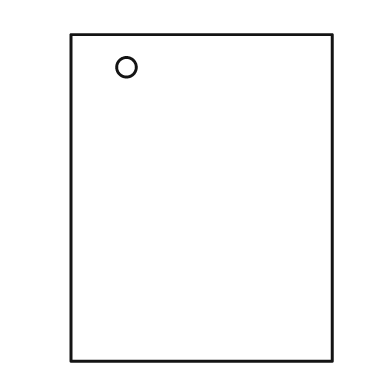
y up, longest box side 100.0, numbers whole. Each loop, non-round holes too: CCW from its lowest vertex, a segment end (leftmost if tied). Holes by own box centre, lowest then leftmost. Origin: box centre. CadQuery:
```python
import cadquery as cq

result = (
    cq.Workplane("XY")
    .moveTo(-40.0, -50.0)
    .lineTo(40.0, -50.0)
    .lineTo(40.0, 50.0)
    .lineTo(-40.0, 50.0)
    .close()
    .moveTo(-23.0, 40.0)
    .circle(3.0)
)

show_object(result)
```